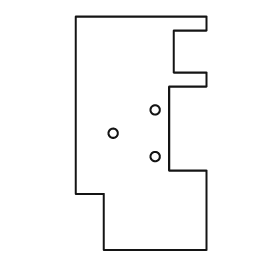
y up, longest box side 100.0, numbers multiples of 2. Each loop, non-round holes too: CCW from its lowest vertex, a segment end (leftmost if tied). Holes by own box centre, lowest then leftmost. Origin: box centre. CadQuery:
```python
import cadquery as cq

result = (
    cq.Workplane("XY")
    .moveTo(-16.0, -50.0)
    .lineTo(28.0, -50.0)
    .lineTo(28.0, -16.0)
    .lineTo(12.0, -16.0)
    .lineTo(12.0, 20.0)
    .lineTo(28.0, 20.0)
    .lineTo(28.0, 26.0)
    .lineTo(14.0, 26.0)
    .lineTo(14.0, 44.0)
    .lineTo(28.0, 44.0)
    .lineTo(28.0, 50.0)
    .lineTo(-28.0, 50.0)
    .lineTo(-28.0, -26.0)
    .lineTo(-16.0, -26.0)
    .close()
    .moveTo(6.0, -10.0)
    .circle(2.0)
    .moveTo(-12.0, 0.0)
    .circle(2.0)
    .moveTo(6.0, 10.0)
    .circle(2.0)
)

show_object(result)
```